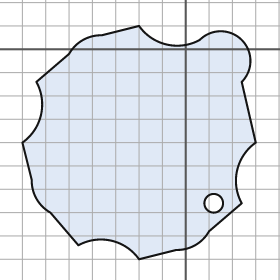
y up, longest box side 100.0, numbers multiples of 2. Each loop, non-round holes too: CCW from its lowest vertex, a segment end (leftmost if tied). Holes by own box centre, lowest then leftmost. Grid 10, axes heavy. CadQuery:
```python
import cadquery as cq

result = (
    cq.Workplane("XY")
    .moveTo(-20.0, -90.0)
    .lineTo(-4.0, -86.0)
    .threePointArc((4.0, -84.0), (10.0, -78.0))
    .lineTo(24.0, -66.0)
    .threePointArc((22.0, -52.0), (30.0, -40.0))
    .lineTo(24.0, -14.0)
    .threePointArc((24.0, 4.0), (6.0, 4.0))
    .threePointArc((-8.0, 2.0), (-20.0, 10.0))
    .lineTo(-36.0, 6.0)
    .threePointArc((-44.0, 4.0), (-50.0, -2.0))
    .lineTo(-64.0, -14.0)
    .threePointArc((-62.0, -28.0), (-70.0, -40.0))
    .lineTo(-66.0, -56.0)
    .threePointArc((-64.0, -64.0), (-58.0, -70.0))
    .lineTo(-46.0, -84.0)
    .threePointArc((-32.0, -82.0), (-20.0, -90.0))
    .close()
    .moveTo(12.0, -66.0)
    .circle(4.0)
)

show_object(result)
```